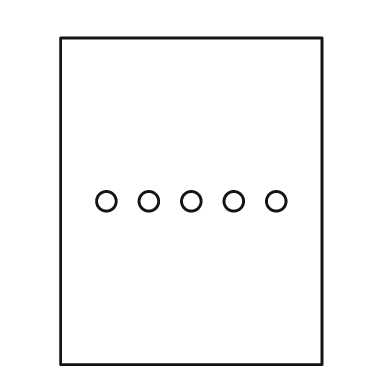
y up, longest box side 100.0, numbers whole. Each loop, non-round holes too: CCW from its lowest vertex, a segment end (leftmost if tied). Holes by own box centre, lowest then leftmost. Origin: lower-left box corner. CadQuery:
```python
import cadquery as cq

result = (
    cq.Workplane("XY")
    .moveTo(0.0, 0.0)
    .lineTo(80.0, 0.0)
    .lineTo(80.0, 100.0)
    .lineTo(0.0, 100.0)
    .close()
    .moveTo(14.0, 50.0)
    .circle(3.0)
    .moveTo(27.0, 50.0)
    .circle(3.0)
    .moveTo(40.0, 50.0)
    .circle(3.0)
    .moveTo(53.0, 50.0)
    .circle(3.0)
    .moveTo(66.0, 50.0)
    .circle(3.0)
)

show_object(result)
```